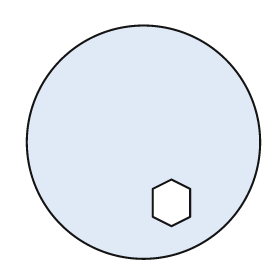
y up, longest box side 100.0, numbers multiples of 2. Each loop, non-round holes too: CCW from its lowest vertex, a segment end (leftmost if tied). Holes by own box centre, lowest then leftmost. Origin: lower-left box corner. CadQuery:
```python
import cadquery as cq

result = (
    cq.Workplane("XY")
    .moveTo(50.0, 50.0)
    .circle(50.0)
    .moveTo(62.0, 14.0)
    .lineTo(70.0, 18.0)
    .lineTo(70.0, 30.0)
    .lineTo(62.0, 34.0)
    .lineTo(54.0, 30.0)
    .lineTo(54.0, 18.0)
    .close()
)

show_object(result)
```